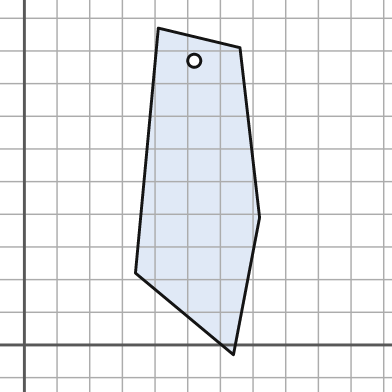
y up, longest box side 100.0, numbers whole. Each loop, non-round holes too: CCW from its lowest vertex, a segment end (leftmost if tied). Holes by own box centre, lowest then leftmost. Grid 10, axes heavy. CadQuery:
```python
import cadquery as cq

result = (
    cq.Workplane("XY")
    .moveTo(64.0, -3.0)
    .lineTo(72.0, 39.0)
    .lineTo(66.0, 91.0)
    .lineTo(41.0, 97.0)
    .lineTo(34.0, 22.0)
    .close()
    .moveTo(52.0, 87.0)
    .circle(2.0)
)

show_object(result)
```